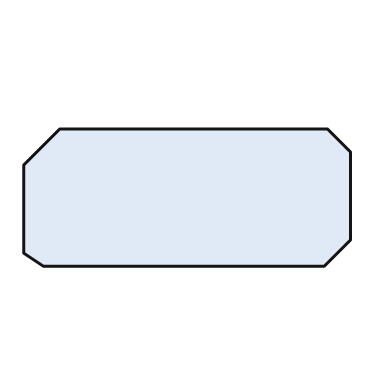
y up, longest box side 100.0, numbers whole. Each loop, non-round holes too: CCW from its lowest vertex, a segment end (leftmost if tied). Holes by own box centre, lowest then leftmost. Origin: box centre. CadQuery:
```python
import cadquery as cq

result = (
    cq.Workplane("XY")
    .moveTo(-44.0, -21.0)
    .lineTo(42.0, -21.0)
    .lineTo(50.0, -13.0)
    .lineTo(50.0, 14.0)
    .lineTo(43.0, 21.0)
    .lineTo(-39.0, 21.0)
    .lineTo(-50.0, 10.0)
    .lineTo(-50.0, -17.0)
    .close()
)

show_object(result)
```